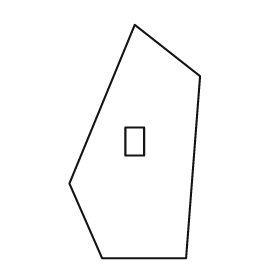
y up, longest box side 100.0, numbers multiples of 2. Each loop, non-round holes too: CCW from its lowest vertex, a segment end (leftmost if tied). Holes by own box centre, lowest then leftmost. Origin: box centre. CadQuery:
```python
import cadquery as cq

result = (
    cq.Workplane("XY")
    .moveTo(-14.0, -50.0)
    .lineTo(22.0, -50.0)
    .lineTo(28.0, 28.0)
    .lineTo(0.0, 50.0)
    .lineTo(-28.0, -18.0)
    .close()
    .moveTo(-4.0, -6.0)
    .lineTo(4.0, -6.0)
    .lineTo(4.0, 6.0)
    .lineTo(-4.0, 6.0)
    .close()
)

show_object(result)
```